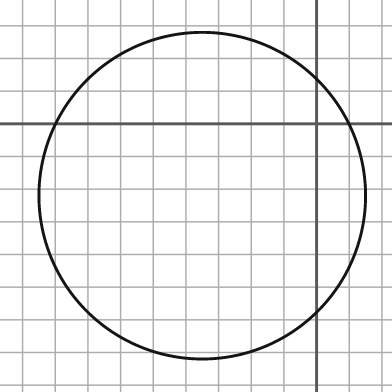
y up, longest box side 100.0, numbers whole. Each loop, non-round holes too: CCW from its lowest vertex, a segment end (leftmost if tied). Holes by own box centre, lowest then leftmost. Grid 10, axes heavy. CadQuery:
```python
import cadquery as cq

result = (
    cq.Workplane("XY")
    .moveTo(-35.0, -22.0)
    .circle(50.0)
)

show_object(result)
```